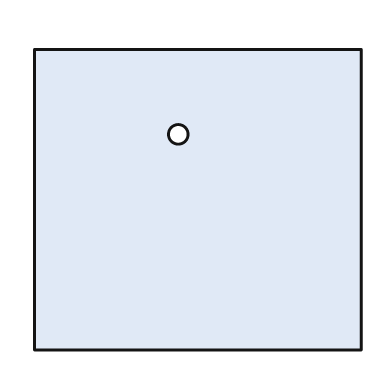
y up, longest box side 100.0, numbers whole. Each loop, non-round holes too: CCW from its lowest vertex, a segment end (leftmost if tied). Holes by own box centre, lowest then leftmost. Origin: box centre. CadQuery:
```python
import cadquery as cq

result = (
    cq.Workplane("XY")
    .moveTo(-50.0, -46.0)
    .lineTo(50.0, -46.0)
    .lineTo(50.0, 46.0)
    .lineTo(-50.0, 46.0)
    .close()
    .moveTo(-6.0, 20.0)
    .circle(3.0)
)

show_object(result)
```